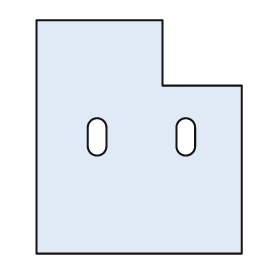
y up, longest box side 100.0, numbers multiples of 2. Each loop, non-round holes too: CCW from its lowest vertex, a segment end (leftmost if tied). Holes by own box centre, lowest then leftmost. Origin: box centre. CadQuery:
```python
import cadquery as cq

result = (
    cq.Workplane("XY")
    .moveTo(-44.0, -50.0)
    .lineTo(44.0, -50.0)
    .lineTo(44.0, 22.0)
    .lineTo(10.0, 22.0)
    .lineTo(10.0, 50.0)
    .lineTo(-44.0, 50.0)
    .close()
    .moveTo(-22.0, -4.0)
    .threePointArc((-18.0, -8.0), (-14.0, -4.0))
    .lineTo(-14.0, 4.0)
    .threePointArc((-18.0, 8.0), (-22.0, 4.0))
    .close()
    .moveTo(16.0, -4.0)
    .threePointArc((20.0, -8.0), (24.0, -4.0))
    .lineTo(24.0, 4.0)
    .threePointArc((20.0, 8.0), (16.0, 4.0))
    .close()
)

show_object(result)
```